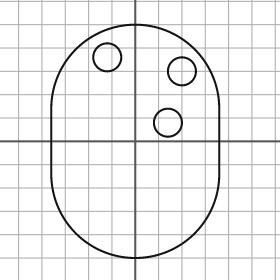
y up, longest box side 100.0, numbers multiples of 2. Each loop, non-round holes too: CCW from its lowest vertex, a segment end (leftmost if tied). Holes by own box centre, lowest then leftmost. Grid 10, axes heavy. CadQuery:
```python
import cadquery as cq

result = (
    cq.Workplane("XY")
    .moveTo(-36.0, -14.0)
    .threePointArc((0.0, -50.0), (36.0, -14.0))
    .lineTo(36.0, 14.0)
    .threePointArc((0.0, 50.0), (-36.0, 14.0))
    .close()
    .moveTo(14.0, 8.0)
    .circle(6.0)
    .moveTo(20.0, 30.0)
    .circle(6.0)
    .moveTo(-12.0, 36.0)
    .circle(6.0)
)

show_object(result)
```